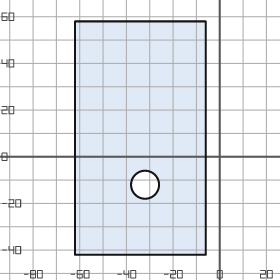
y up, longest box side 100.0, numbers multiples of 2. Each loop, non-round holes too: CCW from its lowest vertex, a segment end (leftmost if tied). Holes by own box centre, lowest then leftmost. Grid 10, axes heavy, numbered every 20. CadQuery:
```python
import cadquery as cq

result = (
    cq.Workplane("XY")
    .moveTo(-62.0, -42.0)
    .lineTo(-6.0, -42.0)
    .lineTo(-6.0, 58.0)
    .lineTo(-62.0, 58.0)
    .close()
    .moveTo(-32.0, -12.0)
    .circle(6.0)
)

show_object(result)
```